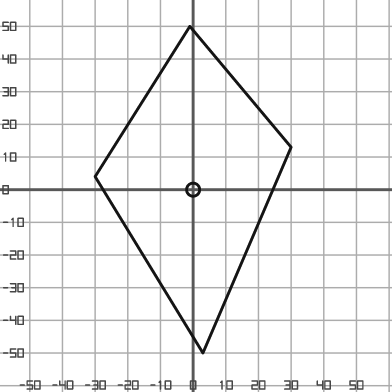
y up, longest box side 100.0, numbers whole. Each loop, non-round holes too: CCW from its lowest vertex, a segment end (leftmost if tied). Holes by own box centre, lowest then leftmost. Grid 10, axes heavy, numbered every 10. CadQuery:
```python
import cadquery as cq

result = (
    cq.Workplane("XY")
    .moveTo(3.0, -50.0)
    .lineTo(30.0, 13.0)
    .lineTo(-1.0, 50.0)
    .lineTo(-30.0, 4.0)
    .close()
    .moveTo(0.0, 0.0)
    .circle(2.0)
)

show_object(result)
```